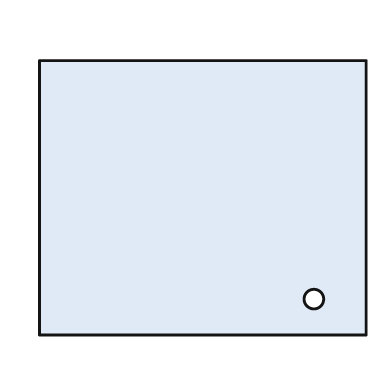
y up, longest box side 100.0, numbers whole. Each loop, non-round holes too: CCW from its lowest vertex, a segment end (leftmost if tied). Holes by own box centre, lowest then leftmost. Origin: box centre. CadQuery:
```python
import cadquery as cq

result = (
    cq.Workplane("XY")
    .moveTo(-50.0, -42.0)
    .lineTo(50.0, -42.0)
    .lineTo(50.0, 42.0)
    .lineTo(-50.0, 42.0)
    .close()
    .moveTo(34.0, -31.0)
    .circle(3.0)
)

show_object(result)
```